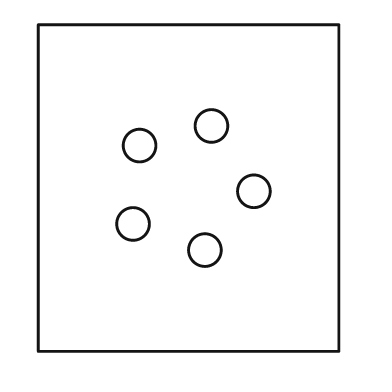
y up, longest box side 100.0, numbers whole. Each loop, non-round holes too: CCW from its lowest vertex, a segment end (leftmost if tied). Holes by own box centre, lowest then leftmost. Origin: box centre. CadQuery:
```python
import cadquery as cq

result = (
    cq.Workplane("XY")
    .moveTo(-46.0, -50.0)
    .lineTo(46.0, -50.0)
    .lineTo(46.0, 50.0)
    .lineTo(-46.0, 50.0)
    .close()
    .moveTo(5.0, -19.0)
    .circle(5.0)
    .moveTo(-17.0, -11.0)
    .circle(5.0)
    .moveTo(20.0, -1.0)
    .circle(5.0)
    .moveTo(-15.0, 13.0)
    .circle(5.0)
    .moveTo(7.0, 19.0)
    .circle(5.0)
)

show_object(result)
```